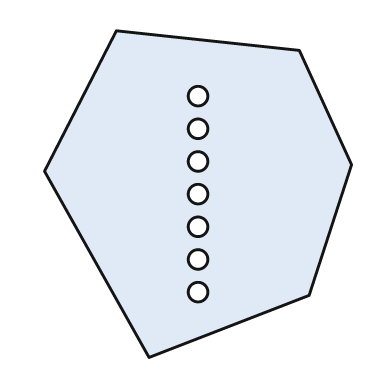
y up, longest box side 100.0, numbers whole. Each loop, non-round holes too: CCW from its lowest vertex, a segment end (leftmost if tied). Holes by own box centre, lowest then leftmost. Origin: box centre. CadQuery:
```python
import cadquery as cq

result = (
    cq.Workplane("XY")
    .moveTo(-15.0, -50.0)
    .lineTo(34.0, -31.0)
    .lineTo(47.0, 9.0)
    .lineTo(31.0, 44.0)
    .lineTo(-25.0, 50.0)
    .lineTo(-47.0, 7.0)
    .close()
    .moveTo(0.0, -30.0)
    .circle(3.0)
    .moveTo(0.0, -20.0)
    .circle(3.0)
    .moveTo(0.0, -10.0)
    .circle(3.0)
    .moveTo(0.0, 0.0)
    .circle(3.0)
    .moveTo(0.0, 10.0)
    .circle(3.0)
    .moveTo(0.0, 20.0)
    .circle(3.0)
    .moveTo(0.0, 30.0)
    .circle(3.0)
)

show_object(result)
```